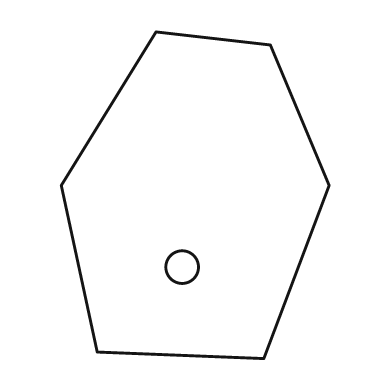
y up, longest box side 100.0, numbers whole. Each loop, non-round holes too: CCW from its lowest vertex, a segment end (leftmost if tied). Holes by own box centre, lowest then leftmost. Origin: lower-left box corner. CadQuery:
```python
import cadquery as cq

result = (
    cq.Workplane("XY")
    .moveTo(62.0, 0.0)
    .lineTo(82.0, 53.0)
    .lineTo(64.0, 96.0)
    .lineTo(29.0, 100.0)
    .lineTo(0.0, 53.0)
    .lineTo(11.0, 2.0)
    .close()
    .moveTo(37.0, 28.0)
    .circle(5.0)
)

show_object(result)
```